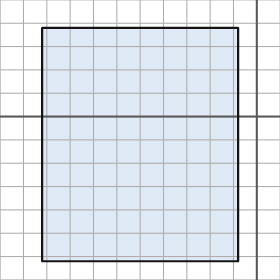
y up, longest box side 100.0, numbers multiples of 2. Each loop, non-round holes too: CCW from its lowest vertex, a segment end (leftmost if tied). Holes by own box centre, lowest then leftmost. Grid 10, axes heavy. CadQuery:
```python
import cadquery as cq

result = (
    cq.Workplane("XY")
    .moveTo(-92.0, -62.0)
    .lineTo(-8.0, -62.0)
    .lineTo(-8.0, 38.0)
    .lineTo(-92.0, 38.0)
    .close()
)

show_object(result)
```